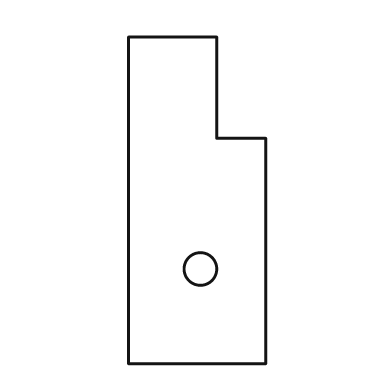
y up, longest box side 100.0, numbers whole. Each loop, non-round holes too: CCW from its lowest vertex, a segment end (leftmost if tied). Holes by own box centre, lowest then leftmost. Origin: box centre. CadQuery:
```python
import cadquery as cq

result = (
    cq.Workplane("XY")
    .moveTo(-21.0, -50.0)
    .lineTo(21.0, -50.0)
    .lineTo(21.0, 19.0)
    .lineTo(6.0, 19.0)
    .lineTo(6.0, 50.0)
    .lineTo(-21.0, 50.0)
    .close()
    .moveTo(1.0, -21.0)
    .circle(5.0)
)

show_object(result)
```